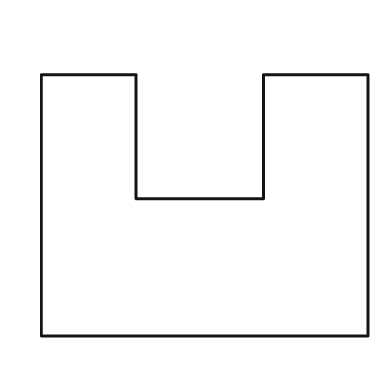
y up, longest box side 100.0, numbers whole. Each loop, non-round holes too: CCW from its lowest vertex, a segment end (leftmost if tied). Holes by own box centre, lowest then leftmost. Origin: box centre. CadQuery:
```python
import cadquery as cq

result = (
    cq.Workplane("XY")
    .moveTo(-50.0, -40.0)
    .lineTo(50.0, -40.0)
    .lineTo(50.0, 40.0)
    .lineTo(18.0, 40.0)
    .lineTo(18.0, 2.0)
    .lineTo(-21.0, 2.0)
    .lineTo(-21.0, 40.0)
    .lineTo(-50.0, 40.0)
    .close()
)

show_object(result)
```